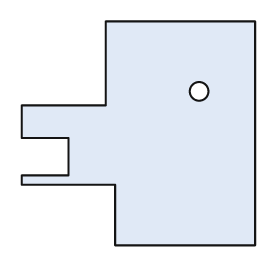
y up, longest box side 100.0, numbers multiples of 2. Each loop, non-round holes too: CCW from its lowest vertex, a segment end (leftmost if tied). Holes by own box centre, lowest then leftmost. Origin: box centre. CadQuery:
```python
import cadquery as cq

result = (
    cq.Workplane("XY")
    .moveTo(-10.0, -48.0)
    .lineTo(50.0, -48.0)
    .lineTo(50.0, 48.0)
    .lineTo(-14.0, 48.0)
    .lineTo(-14.0, 12.0)
    .lineTo(-50.0, 12.0)
    .lineTo(-50.0, -2.0)
    .lineTo(-30.0, -2.0)
    .lineTo(-30.0, -18.0)
    .lineTo(-50.0, -18.0)
    .lineTo(-50.0, -22.0)
    .lineTo(-10.0, -22.0)
    .close()
    .moveTo(26.0, 18.0)
    .circle(4.0)
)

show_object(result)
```